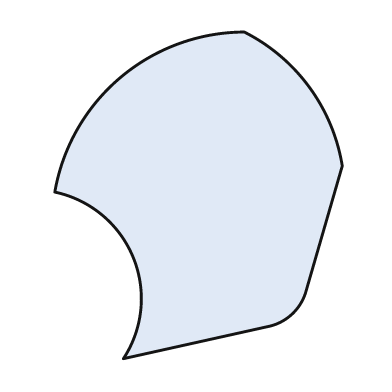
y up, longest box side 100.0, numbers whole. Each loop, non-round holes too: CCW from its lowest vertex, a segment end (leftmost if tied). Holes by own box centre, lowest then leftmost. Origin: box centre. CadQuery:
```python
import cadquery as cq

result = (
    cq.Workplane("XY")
    .moveTo(-23.0, -50.0)
    .lineTo(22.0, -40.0)
    .threePointArc((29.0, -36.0), (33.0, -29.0))
    .lineTo(44.0, 9.0)
    .threePointArc((34.0, 33.0), (14.0, 50.0))
    .threePointArc((-24.0, 36.0), (-44.0, 1.0))
    .threePointArc((-20.0, -19.0), (-23.0, -50.0))
    .close()
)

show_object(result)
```